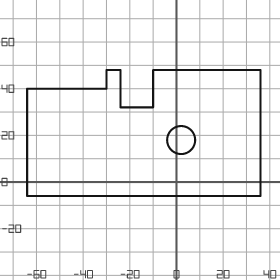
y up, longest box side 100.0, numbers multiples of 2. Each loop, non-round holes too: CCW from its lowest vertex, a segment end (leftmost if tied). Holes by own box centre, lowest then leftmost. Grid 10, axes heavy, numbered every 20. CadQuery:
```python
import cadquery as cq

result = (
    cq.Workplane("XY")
    .moveTo(-64.0, -6.0)
    .lineTo(36.0, -6.0)
    .lineTo(36.0, 48.0)
    .lineTo(-10.0, 48.0)
    .lineTo(-10.0, 32.0)
    .lineTo(-24.0, 32.0)
    .lineTo(-24.0, 48.0)
    .lineTo(-30.0, 48.0)
    .lineTo(-30.0, 40.0)
    .lineTo(-64.0, 40.0)
    .close()
    .moveTo(2.0, 18.0)
    .circle(6.0)
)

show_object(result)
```